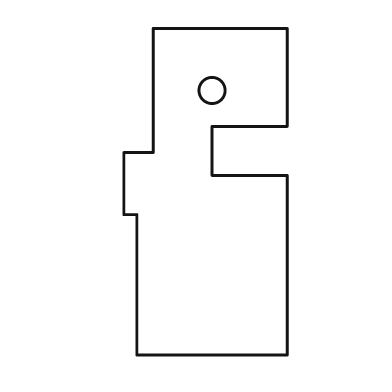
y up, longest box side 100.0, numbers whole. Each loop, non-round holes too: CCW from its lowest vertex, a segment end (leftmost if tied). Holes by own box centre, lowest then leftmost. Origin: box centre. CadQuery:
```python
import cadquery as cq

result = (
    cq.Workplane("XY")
    .moveTo(-21.0, -50.0)
    .lineTo(25.0, -50.0)
    .lineTo(25.0, 5.0)
    .lineTo(2.0, 5.0)
    .lineTo(2.0, 20.0)
    .lineTo(25.0, 20.0)
    .lineTo(25.0, 50.0)
    .lineTo(-16.0, 50.0)
    .lineTo(-16.0, 12.0)
    .lineTo(-25.0, 12.0)
    .lineTo(-25.0, -7.0)
    .lineTo(-21.0, -7.0)
    .close()
    .moveTo(2.0, 31.0)
    .circle(4.0)
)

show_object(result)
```